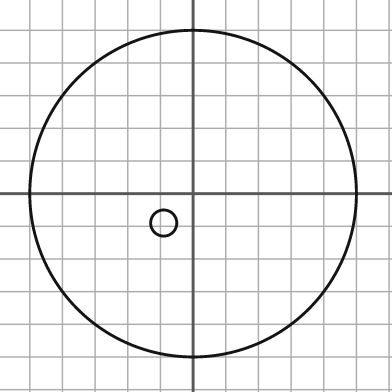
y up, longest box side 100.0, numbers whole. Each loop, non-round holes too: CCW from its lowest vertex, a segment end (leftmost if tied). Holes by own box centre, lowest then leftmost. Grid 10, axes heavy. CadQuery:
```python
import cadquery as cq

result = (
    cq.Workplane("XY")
    .moveTo(0.0, 0.0)
    .circle(50.0)
    .moveTo(-9.0, -9.0)
    .circle(4.0)
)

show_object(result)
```